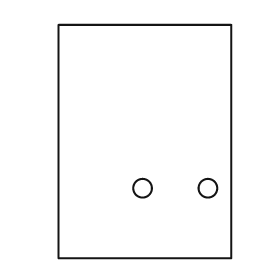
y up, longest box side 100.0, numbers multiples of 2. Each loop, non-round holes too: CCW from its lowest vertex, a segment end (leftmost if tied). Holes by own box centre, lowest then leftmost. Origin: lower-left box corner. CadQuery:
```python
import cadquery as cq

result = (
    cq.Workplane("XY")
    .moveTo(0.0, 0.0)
    .lineTo(74.0, 0.0)
    .lineTo(74.0, 100.0)
    .lineTo(0.0, 100.0)
    .close()
    .moveTo(36.0, 30.0)
    .circle(4.0)
    .moveTo(64.0, 30.0)
    .circle(4.0)
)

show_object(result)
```